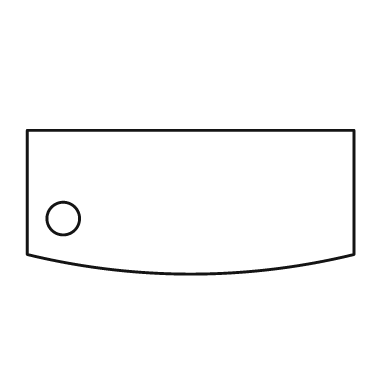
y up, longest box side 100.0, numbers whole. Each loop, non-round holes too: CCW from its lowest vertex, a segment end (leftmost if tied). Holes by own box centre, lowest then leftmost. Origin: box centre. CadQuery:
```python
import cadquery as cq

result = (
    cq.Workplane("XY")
    .moveTo(-50.0, -16.0)
    .threePointArc((0.0, -22.0), (50.0, -16.0))
    .lineTo(50.0, 22.0)
    .lineTo(-50.0, 22.0)
    .close()
    .moveTo(-39.0, -5.0)
    .circle(5.0)
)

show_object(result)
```